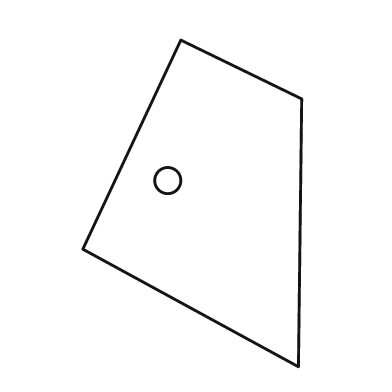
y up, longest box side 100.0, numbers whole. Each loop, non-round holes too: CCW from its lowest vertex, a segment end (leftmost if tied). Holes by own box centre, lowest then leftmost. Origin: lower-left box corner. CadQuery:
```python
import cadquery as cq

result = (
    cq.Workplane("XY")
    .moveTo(66.0, 0.0)
    .lineTo(67.0, 82.0)
    .lineTo(30.0, 100.0)
    .lineTo(0.0, 36.0)
    .close()
    .moveTo(26.0, 57.0)
    .circle(4.0)
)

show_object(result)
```